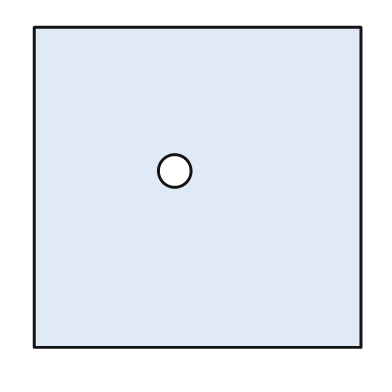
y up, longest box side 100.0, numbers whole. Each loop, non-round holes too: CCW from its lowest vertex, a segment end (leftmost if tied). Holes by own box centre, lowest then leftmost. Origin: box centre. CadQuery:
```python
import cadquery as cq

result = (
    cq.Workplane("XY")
    .moveTo(-50.0, -49.0)
    .lineTo(50.0, -49.0)
    .lineTo(50.0, 49.0)
    .lineTo(-50.0, 49.0)
    .close()
    .moveTo(-7.0, 5.0)
    .circle(5.0)
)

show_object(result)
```